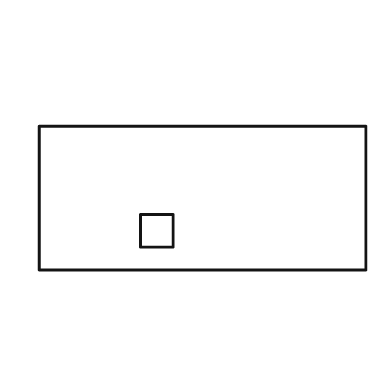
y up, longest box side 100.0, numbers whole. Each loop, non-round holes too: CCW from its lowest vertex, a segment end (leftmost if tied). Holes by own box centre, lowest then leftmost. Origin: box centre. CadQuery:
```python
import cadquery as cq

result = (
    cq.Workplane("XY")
    .moveTo(-50.0, -22.0)
    .lineTo(50.0, -22.0)
    .lineTo(50.0, 22.0)
    .lineTo(-50.0, 22.0)
    .close()
    .moveTo(-19.0, -15.0)
    .lineTo(-9.0, -15.0)
    .lineTo(-9.0, -5.0)
    .lineTo(-19.0, -5.0)
    .close()
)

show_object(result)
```